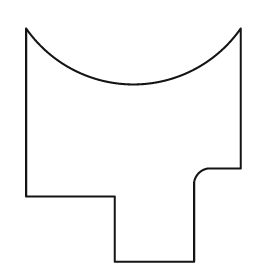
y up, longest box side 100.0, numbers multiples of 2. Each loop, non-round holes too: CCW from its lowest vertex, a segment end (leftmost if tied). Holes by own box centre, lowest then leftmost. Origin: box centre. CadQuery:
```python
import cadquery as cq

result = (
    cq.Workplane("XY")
    .moveTo(-8.0, -50.0)
    .lineTo(26.0, -50.0)
    .lineTo(26.0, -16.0)
    .threePointArc((28.0, -12.0), (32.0, -10.0))
    .lineTo(46.0, -10.0)
    .lineTo(46.0, 50.0)
    .threePointArc((0.0, 26.0), (-46.0, 50.0))
    .lineTo(-46.0, -22.0)
    .lineTo(-8.0, -22.0)
    .close()
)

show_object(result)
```